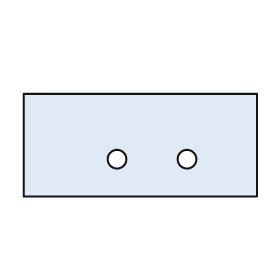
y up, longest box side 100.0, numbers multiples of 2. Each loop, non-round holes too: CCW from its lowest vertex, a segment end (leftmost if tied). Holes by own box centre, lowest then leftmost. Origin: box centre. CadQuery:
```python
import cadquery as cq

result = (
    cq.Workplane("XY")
    .moveTo(-50.0, -22.0)
    .lineTo(50.0, -22.0)
    .lineTo(50.0, 22.0)
    .lineTo(-50.0, 22.0)
    .close()
    .moveTo(-10.0, -6.0)
    .circle(4.0)
    .moveTo(20.0, -6.0)
    .circle(4.0)
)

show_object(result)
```